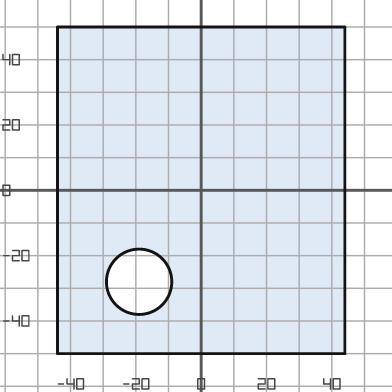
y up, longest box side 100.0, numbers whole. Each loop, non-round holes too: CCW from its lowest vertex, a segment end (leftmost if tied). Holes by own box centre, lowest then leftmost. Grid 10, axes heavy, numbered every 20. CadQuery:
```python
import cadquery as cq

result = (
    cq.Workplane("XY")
    .moveTo(-44.0, -50.0)
    .lineTo(44.0, -50.0)
    .lineTo(44.0, 50.0)
    .lineTo(-44.0, 50.0)
    .close()
    .moveTo(-19.0, -28.0)
    .circle(10.0)
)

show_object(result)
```